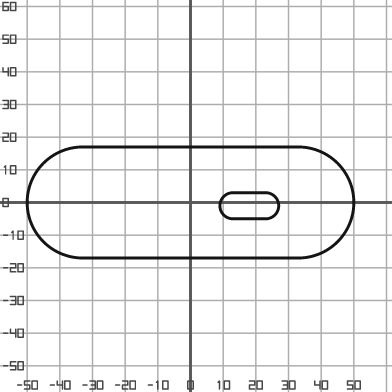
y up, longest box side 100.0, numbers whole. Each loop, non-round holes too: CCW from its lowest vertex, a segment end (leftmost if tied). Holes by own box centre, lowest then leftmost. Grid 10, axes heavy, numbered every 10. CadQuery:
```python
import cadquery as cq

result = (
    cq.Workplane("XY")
    .moveTo(-33.0, -17.0)
    .lineTo(33.0, -17.0)
    .threePointArc((50.0, 0.0), (33.0, 17.0))
    .lineTo(-33.0, 17.0)
    .threePointArc((-50.0, 0.0), (-33.0, -17.0))
    .close()
    .moveTo(13.0, -5.0)
    .lineTo(23.0, -5.0)
    .threePointArc((27.0, -1.0), (23.0, 3.0))
    .lineTo(13.0, 3.0)
    .threePointArc((9.0, -1.0), (13.0, -5.0))
    .close()
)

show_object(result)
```